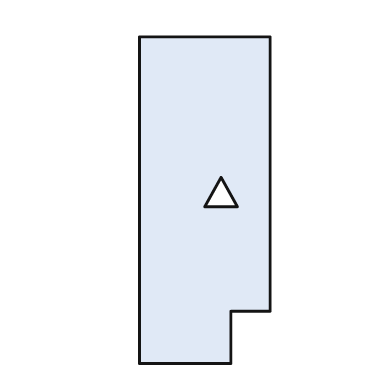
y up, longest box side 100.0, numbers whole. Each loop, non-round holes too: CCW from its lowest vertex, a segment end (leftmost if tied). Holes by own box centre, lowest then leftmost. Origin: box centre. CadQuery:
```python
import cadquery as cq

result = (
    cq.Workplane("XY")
    .moveTo(-20.0, -50.0)
    .lineTo(8.0, -50.0)
    .lineTo(8.0, -34.0)
    .lineTo(20.0, -34.0)
    .lineTo(20.0, 50.0)
    .lineTo(-20.0, 50.0)
    .close()
    .moveTo(0.0, -2.0)
    .lineTo(10.0, -2.0)
    .lineTo(5.0, 7.0)
    .close()
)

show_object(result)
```